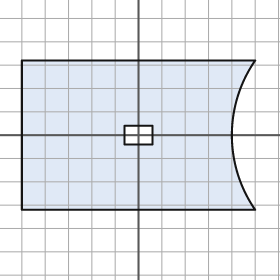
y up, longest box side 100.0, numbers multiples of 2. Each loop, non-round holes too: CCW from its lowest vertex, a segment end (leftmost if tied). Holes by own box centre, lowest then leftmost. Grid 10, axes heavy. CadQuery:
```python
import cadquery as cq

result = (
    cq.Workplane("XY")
    .moveTo(-50.0, -32.0)
    .lineTo(50.0, -32.0)
    .threePointArc((40.0, 0.0), (50.0, 32.0))
    .lineTo(-50.0, 32.0)
    .close()
    .moveTo(-6.0, -4.0)
    .lineTo(6.0, -4.0)
    .lineTo(6.0, 4.0)
    .lineTo(-6.0, 4.0)
    .close()
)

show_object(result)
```